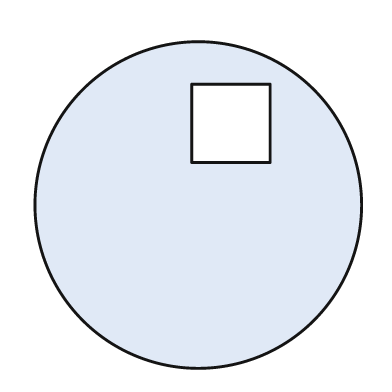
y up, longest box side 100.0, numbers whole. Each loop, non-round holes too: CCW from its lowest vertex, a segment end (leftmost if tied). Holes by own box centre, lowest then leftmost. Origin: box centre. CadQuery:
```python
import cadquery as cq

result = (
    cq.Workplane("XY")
    .moveTo(0.0, 0.0)
    .circle(50.0)
    .moveTo(-2.0, 13.0)
    .lineTo(22.0, 13.0)
    .lineTo(22.0, 37.0)
    .lineTo(-2.0, 37.0)
    .close()
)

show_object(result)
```